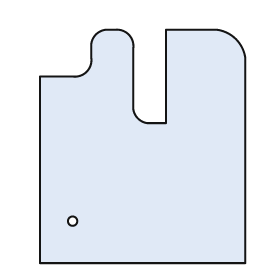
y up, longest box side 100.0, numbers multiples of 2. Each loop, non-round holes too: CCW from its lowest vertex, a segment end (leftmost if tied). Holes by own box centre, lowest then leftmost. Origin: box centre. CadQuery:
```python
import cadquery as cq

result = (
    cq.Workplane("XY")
    .moveTo(-44.0, -50.0)
    .lineTo(44.0, -50.0)
    .lineTo(44.0, 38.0)
    .threePointArc((40.0, 46.0), (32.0, 50.0))
    .lineTo(10.0, 50.0)
    .lineTo(10.0, 10.0)
    .lineTo(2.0, 10.0)
    .threePointArc((-2.0, 12.0), (-4.0, 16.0))
    .lineTo(-4.0, 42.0)
    .threePointArc((-6.0, 48.0), (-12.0, 50.0))
    .lineTo(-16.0, 50.0)
    .threePointArc((-20.0, 48.0), (-22.0, 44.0))
    .lineTo(-22.0, 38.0)
    .threePointArc((-24.0, 32.0), (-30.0, 30.0))
    .lineTo(-44.0, 30.0)
    .close()
    .moveTo(-30.0, -32.0)
    .circle(2.0)
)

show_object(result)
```